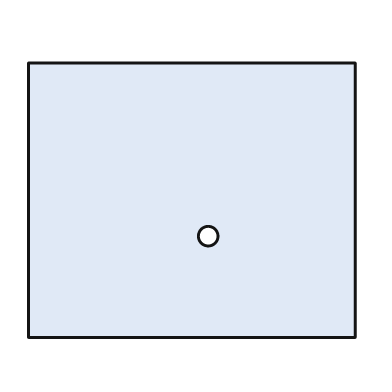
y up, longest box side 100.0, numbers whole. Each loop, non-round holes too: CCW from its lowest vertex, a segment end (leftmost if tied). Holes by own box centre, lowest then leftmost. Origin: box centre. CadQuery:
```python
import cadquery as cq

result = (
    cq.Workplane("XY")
    .moveTo(-50.0, -42.0)
    .lineTo(50.0, -42.0)
    .lineTo(50.0, 42.0)
    .lineTo(-50.0, 42.0)
    .close()
    .moveTo(5.0, -11.0)
    .circle(3.0)
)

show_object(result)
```